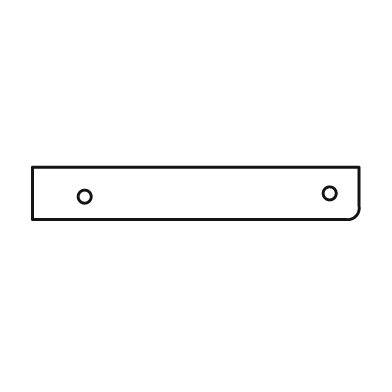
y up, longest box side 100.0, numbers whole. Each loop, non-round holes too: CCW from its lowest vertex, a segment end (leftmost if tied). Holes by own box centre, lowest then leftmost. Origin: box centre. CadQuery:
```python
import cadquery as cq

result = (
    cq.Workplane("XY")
    .moveTo(-50.0, -8.0)
    .lineTo(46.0, -8.0)
    .threePointArc((49.0, -7.0), (50.0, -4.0))
    .lineTo(50.0, 8.0)
    .lineTo(-50.0, 8.0)
    .close()
    .moveTo(-34.0, -1.0)
    .circle(2.0)
    .moveTo(41.0, 0.0)
    .circle(2.0)
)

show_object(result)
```